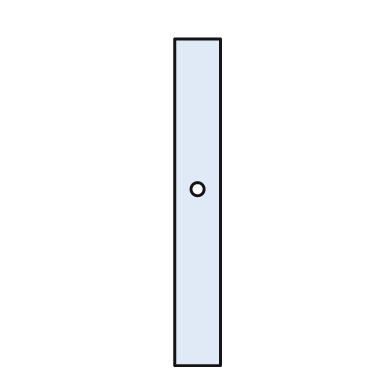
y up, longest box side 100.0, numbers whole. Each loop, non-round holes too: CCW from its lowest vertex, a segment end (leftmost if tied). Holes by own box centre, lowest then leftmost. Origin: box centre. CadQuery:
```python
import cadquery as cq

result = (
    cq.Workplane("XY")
    .moveTo(-7.0, -50.0)
    .lineTo(7.0, -50.0)
    .lineTo(7.0, 50.0)
    .lineTo(-7.0, 50.0)
    .close()
    .moveTo(0.0, 4.0)
    .circle(2.0)
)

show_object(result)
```